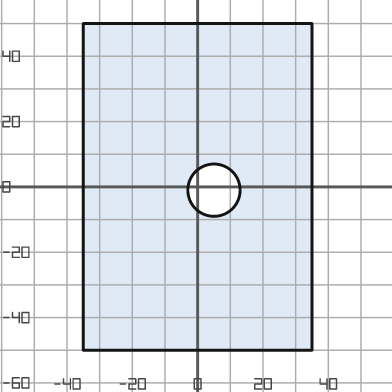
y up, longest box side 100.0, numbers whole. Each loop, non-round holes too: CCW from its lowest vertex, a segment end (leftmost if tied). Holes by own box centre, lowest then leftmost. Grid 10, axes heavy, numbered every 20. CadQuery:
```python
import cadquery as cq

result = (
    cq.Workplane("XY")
    .moveTo(-35.0, -50.0)
    .lineTo(35.0, -50.0)
    .lineTo(35.0, 50.0)
    .lineTo(-35.0, 50.0)
    .close()
    .moveTo(5.0, -1.0)
    .circle(8.0)
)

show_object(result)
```